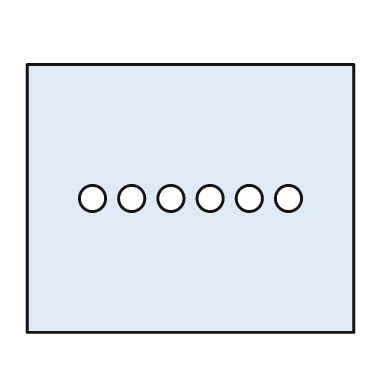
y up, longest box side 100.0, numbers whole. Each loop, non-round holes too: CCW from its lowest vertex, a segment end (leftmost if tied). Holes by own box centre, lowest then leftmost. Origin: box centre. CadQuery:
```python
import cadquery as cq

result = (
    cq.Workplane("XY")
    .moveTo(-50.0, -41.0)
    .lineTo(50.0, -41.0)
    .lineTo(50.0, 41.0)
    .lineTo(-50.0, 41.0)
    .close()
    .moveTo(-30.0, 0.0)
    .circle(4.0)
    .moveTo(-18.0, 0.0)
    .circle(4.0)
    .moveTo(-6.0, 0.0)
    .circle(4.0)
    .moveTo(6.0, 0.0)
    .circle(4.0)
    .moveTo(18.0, 0.0)
    .circle(4.0)
    .moveTo(30.0, 0.0)
    .circle(4.0)
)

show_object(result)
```